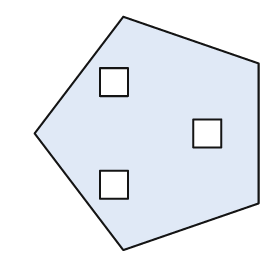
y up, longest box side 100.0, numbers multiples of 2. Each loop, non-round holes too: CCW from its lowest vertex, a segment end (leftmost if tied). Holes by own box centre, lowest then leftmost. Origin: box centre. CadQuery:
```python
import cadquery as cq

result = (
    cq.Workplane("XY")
    .moveTo(-10.0, -50.0)
    .lineTo(48.0, -30.0)
    .lineTo(48.0, 30.0)
    .lineTo(-10.0, 50.0)
    .lineTo(-48.0, 0.0)
    .close()
    .moveTo(-20.0, -28.0)
    .lineTo(-8.0, -28.0)
    .lineTo(-8.0, -16.0)
    .lineTo(-20.0, -16.0)
    .close()
    .moveTo(20.0, -6.0)
    .lineTo(32.0, -6.0)
    .lineTo(32.0, 6.0)
    .lineTo(20.0, 6.0)
    .close()
    .moveTo(-20.0, 16.0)
    .lineTo(-8.0, 16.0)
    .lineTo(-8.0, 28.0)
    .lineTo(-20.0, 28.0)
    .close()
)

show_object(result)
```